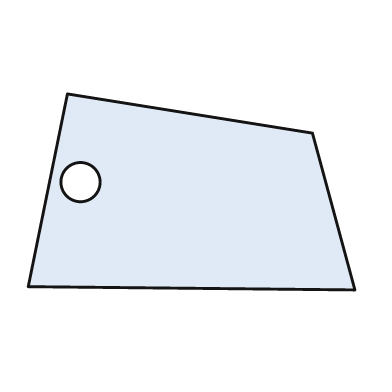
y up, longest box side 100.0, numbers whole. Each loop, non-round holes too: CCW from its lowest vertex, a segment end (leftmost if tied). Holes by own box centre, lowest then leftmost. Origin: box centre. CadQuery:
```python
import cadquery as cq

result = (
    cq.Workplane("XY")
    .moveTo(50.0, -30.0)
    .lineTo(37.0, 18.0)
    .lineTo(-38.0, 30.0)
    .lineTo(-50.0, -29.0)
    .close()
    .moveTo(-34.0, 3.0)
    .circle(6.0)
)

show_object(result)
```